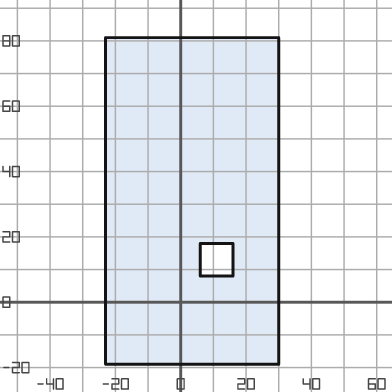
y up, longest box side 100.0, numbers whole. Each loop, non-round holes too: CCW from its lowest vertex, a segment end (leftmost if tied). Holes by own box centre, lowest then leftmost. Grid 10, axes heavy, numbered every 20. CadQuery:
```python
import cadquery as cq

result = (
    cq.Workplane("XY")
    .moveTo(-23.0, -19.0)
    .lineTo(30.0, -19.0)
    .lineTo(30.0, 81.0)
    .lineTo(-23.0, 81.0)
    .close()
    .moveTo(6.0, 8.0)
    .lineTo(16.0, 8.0)
    .lineTo(16.0, 18.0)
    .lineTo(6.0, 18.0)
    .close()
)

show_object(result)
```